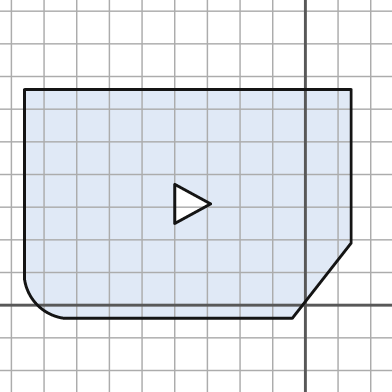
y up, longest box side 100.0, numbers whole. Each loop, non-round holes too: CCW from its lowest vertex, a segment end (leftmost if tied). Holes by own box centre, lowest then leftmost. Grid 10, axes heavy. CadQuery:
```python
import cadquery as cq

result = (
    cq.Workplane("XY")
    .moveTo(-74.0, -4.0)
    .lineTo(-4.0, -4.0)
    .lineTo(14.0, 19.0)
    .lineTo(14.0, 66.0)
    .lineTo(-86.0, 66.0)
    .lineTo(-86.0, 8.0)
    .threePointArc((-82.0, 0.0), (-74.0, -4.0))
    .close()
    .moveTo(-40.0, 25.0)
    .lineTo(-29.0, 31.0)
    .lineTo(-40.0, 37.0)
    .close()
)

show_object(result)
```